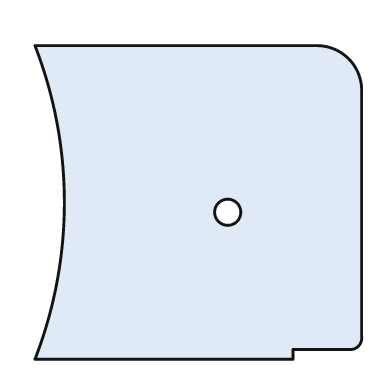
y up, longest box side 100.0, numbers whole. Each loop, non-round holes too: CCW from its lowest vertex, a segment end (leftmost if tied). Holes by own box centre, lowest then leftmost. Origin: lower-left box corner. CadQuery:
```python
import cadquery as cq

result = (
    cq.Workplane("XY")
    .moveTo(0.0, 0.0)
    .lineTo(79.0, 0.0)
    .lineTo(79.0, 3.0)
    .lineTo(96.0, 3.0)
    .threePointArc((99.0, 4.0), (100.0, 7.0))
    .lineTo(100.0, 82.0)
    .threePointArc((96.0, 92.0), (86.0, 96.0))
    .lineTo(0.0, 96.0)
    .threePointArc((9.0, 48.0), (0.0, 0.0))
    .close()
    .moveTo(59.0, 45.0)
    .circle(4.0)
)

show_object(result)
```